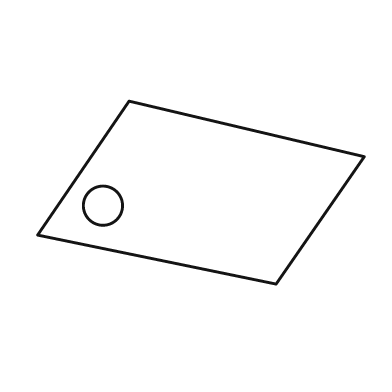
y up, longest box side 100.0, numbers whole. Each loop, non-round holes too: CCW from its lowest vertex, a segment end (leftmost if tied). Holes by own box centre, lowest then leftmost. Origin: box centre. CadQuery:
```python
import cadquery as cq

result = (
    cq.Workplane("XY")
    .moveTo(23.0, -28.0)
    .lineTo(50.0, 11.0)
    .lineTo(-22.0, 28.0)
    .lineTo(-50.0, -13.0)
    .close()
    .moveTo(-30.0, -4.0)
    .circle(6.0)
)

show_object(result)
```